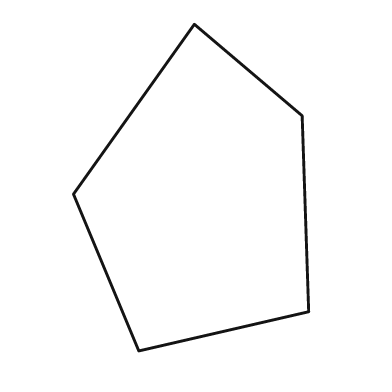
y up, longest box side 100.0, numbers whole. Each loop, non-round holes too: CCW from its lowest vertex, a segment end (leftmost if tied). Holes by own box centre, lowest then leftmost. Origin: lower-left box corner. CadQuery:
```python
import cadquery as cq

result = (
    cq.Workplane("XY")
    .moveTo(20.0, 0.0)
    .lineTo(72.0, 12.0)
    .lineTo(70.0, 72.0)
    .lineTo(37.0, 100.0)
    .lineTo(0.0, 48.0)
    .close()
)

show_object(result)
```